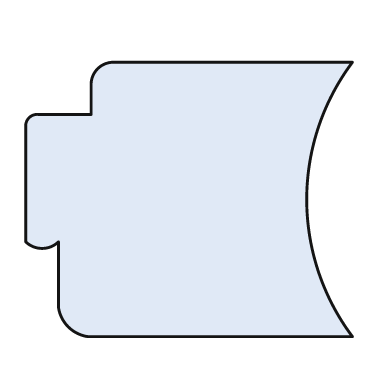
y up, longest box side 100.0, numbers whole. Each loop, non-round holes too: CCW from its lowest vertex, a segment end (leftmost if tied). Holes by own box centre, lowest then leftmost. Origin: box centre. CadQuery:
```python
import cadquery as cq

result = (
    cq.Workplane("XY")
    .moveTo(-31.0, -42.0)
    .lineTo(50.0, -42.0)
    .threePointArc((36.0, 0.0), (50.0, 42.0))
    .lineTo(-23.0, 42.0)
    .threePointArc((-28.0, 40.0), (-30.0, 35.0))
    .lineTo(-30.0, 26.0)
    .lineTo(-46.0, 26.0)
    .threePointArc((-49.0, 25.0), (-50.0, 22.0))
    .lineTo(-50.0, -13.0)
    .threePointArc((-45.0, -15.0), (-40.0, -13.0))
    .lineTo(-40.0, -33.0)
    .threePointArc((-37.0, -39.0), (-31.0, -42.0))
    .close()
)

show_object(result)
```